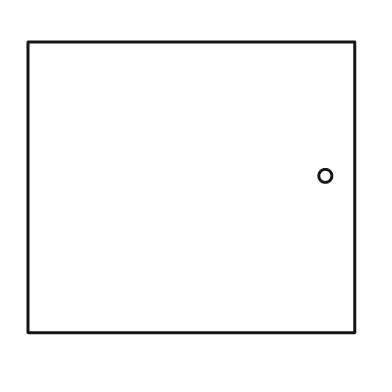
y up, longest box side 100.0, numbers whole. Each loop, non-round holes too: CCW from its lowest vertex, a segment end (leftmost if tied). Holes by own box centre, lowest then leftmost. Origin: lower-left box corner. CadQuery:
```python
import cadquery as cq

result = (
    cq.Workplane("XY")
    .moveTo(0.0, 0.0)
    .lineTo(100.0, 0.0)
    .lineTo(100.0, 89.0)
    .lineTo(0.0, 89.0)
    .close()
    .moveTo(91.0, 48.0)
    .circle(2.0)
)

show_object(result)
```